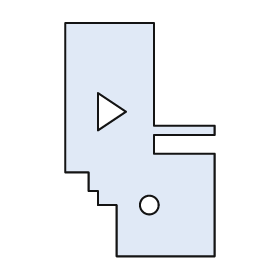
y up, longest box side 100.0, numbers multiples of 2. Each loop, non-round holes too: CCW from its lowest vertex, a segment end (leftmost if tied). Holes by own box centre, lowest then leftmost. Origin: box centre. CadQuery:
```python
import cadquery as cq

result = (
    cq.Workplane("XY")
    .moveTo(-10.0, -50.0)
    .lineTo(32.0, -50.0)
    .lineTo(32.0, -6.0)
    .lineTo(6.0, -6.0)
    .lineTo(6.0, 2.0)
    .lineTo(32.0, 2.0)
    .lineTo(32.0, 6.0)
    .lineTo(6.0, 6.0)
    .lineTo(6.0, 50.0)
    .lineTo(-32.0, 50.0)
    .lineTo(-32.0, -14.0)
    .lineTo(-22.0, -14.0)
    .lineTo(-22.0, -22.0)
    .lineTo(-18.0, -22.0)
    .lineTo(-18.0, -28.0)
    .lineTo(-10.0, -28.0)
    .close()
    .moveTo(4.0, -28.0)
    .circle(4.0)
    .moveTo(-18.0, 4.0)
    .lineTo(-6.0, 12.0)
    .lineTo(-18.0, 20.0)
    .close()
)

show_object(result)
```